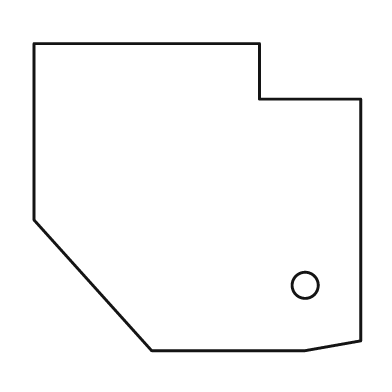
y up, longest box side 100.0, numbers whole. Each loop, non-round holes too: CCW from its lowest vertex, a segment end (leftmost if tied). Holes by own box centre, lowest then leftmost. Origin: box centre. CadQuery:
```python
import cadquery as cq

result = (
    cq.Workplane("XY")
    .moveTo(-14.0, -47.0)
    .lineTo(33.0, -47.0)
    .lineTo(50.0, -44.0)
    .lineTo(50.0, 30.0)
    .lineTo(19.0, 30.0)
    .lineTo(19.0, 47.0)
    .lineTo(-50.0, 47.0)
    .lineTo(-50.0, -7.0)
    .close()
    .moveTo(33.0, -27.0)
    .circle(4.0)
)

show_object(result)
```